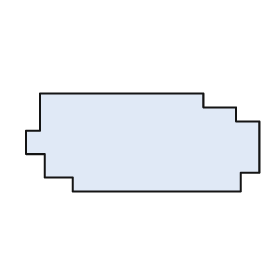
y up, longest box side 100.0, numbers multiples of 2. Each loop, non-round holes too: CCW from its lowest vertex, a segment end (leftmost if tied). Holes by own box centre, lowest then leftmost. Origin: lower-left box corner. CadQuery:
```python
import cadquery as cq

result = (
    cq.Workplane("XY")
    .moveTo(20.0, 0.0)
    .lineTo(92.0, 0.0)
    .lineTo(92.0, 8.0)
    .lineTo(100.0, 8.0)
    .lineTo(100.0, 30.0)
    .lineTo(90.0, 30.0)
    .lineTo(90.0, 36.0)
    .lineTo(76.0, 36.0)
    .lineTo(76.0, 42.0)
    .lineTo(6.0, 42.0)
    .lineTo(6.0, 26.0)
    .lineTo(0.0, 26.0)
    .lineTo(0.0, 16.0)
    .lineTo(8.0, 16.0)
    .lineTo(8.0, 6.0)
    .lineTo(20.0, 6.0)
    .close()
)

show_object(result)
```